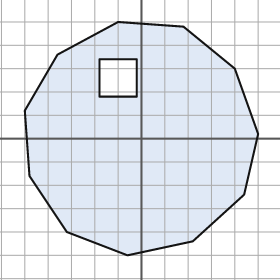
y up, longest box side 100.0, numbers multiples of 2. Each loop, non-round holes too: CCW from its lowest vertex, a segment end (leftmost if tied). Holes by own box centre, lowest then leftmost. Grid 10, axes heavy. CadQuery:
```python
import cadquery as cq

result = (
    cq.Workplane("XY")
    .moveTo(-6.0, -50.0)
    .lineTo(22.0, -44.0)
    .lineTo(44.0, -24.0)
    .lineTo(50.0, 2.0)
    .lineTo(40.0, 30.0)
    .lineTo(18.0, 48.0)
    .lineTo(-10.0, 50.0)
    .lineTo(-36.0, 36.0)
    .lineTo(-50.0, 12.0)
    .lineTo(-48.0, -16.0)
    .lineTo(-32.0, -40.0)
    .close()
    .moveTo(-18.0, 18.0)
    .lineTo(-2.0, 18.0)
    .lineTo(-2.0, 34.0)
    .lineTo(-18.0, 34.0)
    .close()
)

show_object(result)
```